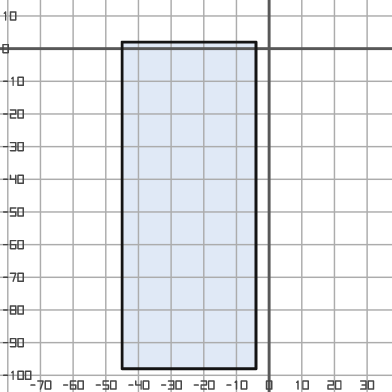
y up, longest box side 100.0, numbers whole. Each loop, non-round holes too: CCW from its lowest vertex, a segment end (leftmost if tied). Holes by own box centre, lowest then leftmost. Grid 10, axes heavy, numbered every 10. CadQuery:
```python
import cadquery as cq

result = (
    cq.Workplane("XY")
    .moveTo(-45.0, -98.0)
    .lineTo(-4.0, -98.0)
    .lineTo(-4.0, 2.0)
    .lineTo(-45.0, 2.0)
    .close()
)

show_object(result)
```